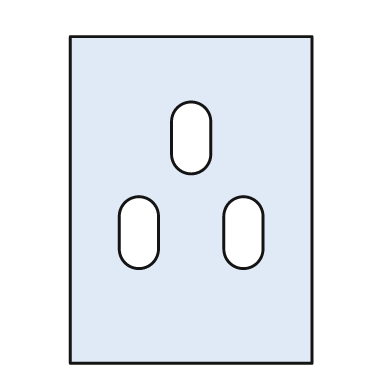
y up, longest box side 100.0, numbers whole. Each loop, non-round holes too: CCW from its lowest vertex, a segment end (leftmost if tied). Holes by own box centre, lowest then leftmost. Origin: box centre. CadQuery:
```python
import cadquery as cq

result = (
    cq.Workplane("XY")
    .moveTo(-37.0, -50.0)
    .lineTo(37.0, -50.0)
    .lineTo(37.0, 50.0)
    .lineTo(-37.0, 50.0)
    .close()
    .moveTo(-22.0, -15.0)
    .threePointArc((-16.0, -21.0), (-10.0, -15.0))
    .lineTo(-10.0, -5.0)
    .threePointArc((-16.0, 1.0), (-22.0, -5.0))
    .close()
    .moveTo(10.0, -15.0)
    .threePointArc((16.0, -21.0), (22.0, -15.0))
    .lineTo(22.0, -5.0)
    .threePointArc((16.0, 1.0), (10.0, -5.0))
    .close()
    .moveTo(-6.0, 14.0)
    .threePointArc((0.0, 8.0), (6.0, 14.0))
    .lineTo(6.0, 24.0)
    .threePointArc((0.0, 30.0), (-6.0, 24.0))
    .close()
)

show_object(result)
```